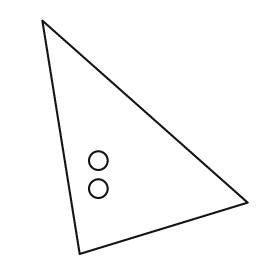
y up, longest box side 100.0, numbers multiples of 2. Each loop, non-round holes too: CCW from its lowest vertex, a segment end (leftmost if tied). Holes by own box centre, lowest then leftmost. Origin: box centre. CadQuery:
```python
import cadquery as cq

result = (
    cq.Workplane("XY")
    .moveTo(-28.0, -50.0)
    .lineTo(44.0, -28.0)
    .lineTo(-44.0, 50.0)
    .close()
    .moveTo(-20.0, -22.0)
    .circle(4.0)
    .moveTo(-20.0, -10.0)
    .circle(4.0)
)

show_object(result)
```